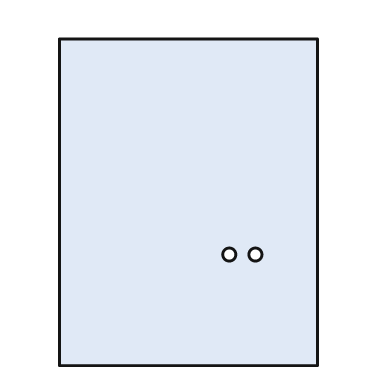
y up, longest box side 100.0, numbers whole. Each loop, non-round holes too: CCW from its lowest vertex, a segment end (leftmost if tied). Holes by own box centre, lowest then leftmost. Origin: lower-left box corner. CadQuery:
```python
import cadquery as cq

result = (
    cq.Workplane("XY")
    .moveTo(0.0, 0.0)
    .lineTo(79.0, 0.0)
    .lineTo(79.0, 100.0)
    .lineTo(0.0, 100.0)
    .close()
    .moveTo(52.0, 34.0)
    .circle(2.0)
    .moveTo(60.0, 34.0)
    .circle(2.0)
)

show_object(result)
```